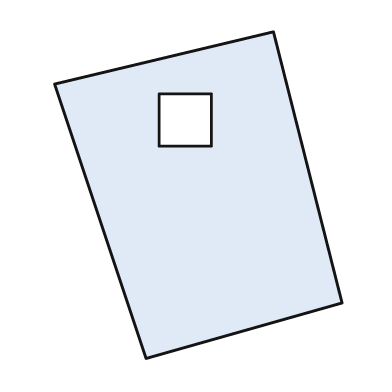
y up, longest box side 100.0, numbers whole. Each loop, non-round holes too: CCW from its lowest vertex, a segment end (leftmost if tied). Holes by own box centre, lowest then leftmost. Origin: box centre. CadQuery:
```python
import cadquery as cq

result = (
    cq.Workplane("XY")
    .moveTo(-16.0, -50.0)
    .lineTo(44.0, -33.0)
    .lineTo(23.0, 50.0)
    .lineTo(-44.0, 34.0)
    .close()
    .moveTo(-12.0, 15.0)
    .lineTo(4.0, 15.0)
    .lineTo(4.0, 31.0)
    .lineTo(-12.0, 31.0)
    .close()
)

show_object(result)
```